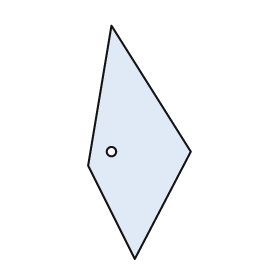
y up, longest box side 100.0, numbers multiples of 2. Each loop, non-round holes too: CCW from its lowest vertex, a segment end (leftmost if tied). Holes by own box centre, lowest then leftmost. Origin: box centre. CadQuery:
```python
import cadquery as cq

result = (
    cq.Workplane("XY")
    .moveTo(-2.0, -50.0)
    .lineTo(22.0, -4.0)
    .lineTo(-12.0, 50.0)
    .lineTo(-22.0, -10.0)
    .close()
    .moveTo(-12.0, -4.0)
    .circle(2.0)
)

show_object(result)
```